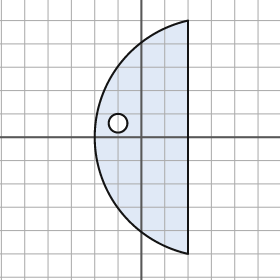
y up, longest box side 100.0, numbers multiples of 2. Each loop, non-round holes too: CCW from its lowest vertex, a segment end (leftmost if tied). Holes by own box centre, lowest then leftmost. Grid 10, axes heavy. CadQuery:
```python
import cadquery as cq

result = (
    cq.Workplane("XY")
    .moveTo(20.0, -50.0)
    .lineTo(20.0, 50.0)
    .threePointArc((-20.0, 0.0), (20.0, -50.0))
    .close()
    .moveTo(-10.0, 6.0)
    .circle(4.0)
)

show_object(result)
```